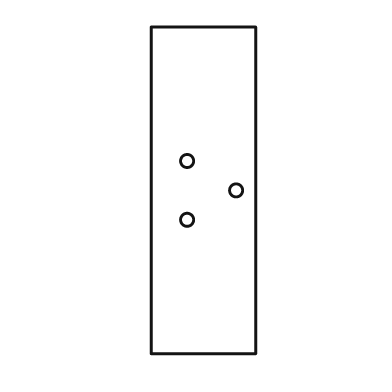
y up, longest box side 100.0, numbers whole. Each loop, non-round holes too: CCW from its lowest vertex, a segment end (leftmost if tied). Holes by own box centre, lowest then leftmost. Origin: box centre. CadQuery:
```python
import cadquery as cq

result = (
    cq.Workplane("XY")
    .moveTo(-16.0, -50.0)
    .lineTo(16.0, -50.0)
    .lineTo(16.0, 50.0)
    .lineTo(-16.0, 50.0)
    .close()
    .moveTo(-5.0, -9.0)
    .circle(2.0)
    .moveTo(10.0, 0.0)
    .circle(2.0)
    .moveTo(-5.0, 9.0)
    .circle(2.0)
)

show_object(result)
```